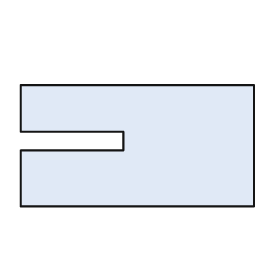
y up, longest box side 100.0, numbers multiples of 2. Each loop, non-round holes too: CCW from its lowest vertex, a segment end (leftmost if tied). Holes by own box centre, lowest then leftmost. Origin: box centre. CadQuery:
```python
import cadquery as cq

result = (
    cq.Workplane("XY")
    .moveTo(-50.0, -26.0)
    .lineTo(50.0, -26.0)
    .lineTo(50.0, 26.0)
    .lineTo(-50.0, 26.0)
    .lineTo(-50.0, 6.0)
    .lineTo(-6.0, 6.0)
    .lineTo(-6.0, -2.0)
    .lineTo(-50.0, -2.0)
    .close()
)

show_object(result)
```